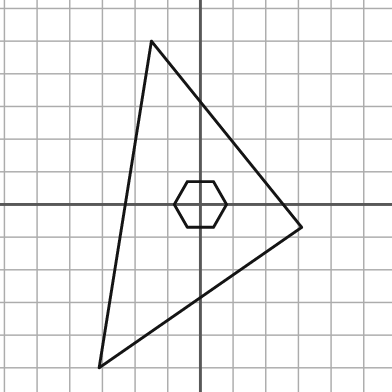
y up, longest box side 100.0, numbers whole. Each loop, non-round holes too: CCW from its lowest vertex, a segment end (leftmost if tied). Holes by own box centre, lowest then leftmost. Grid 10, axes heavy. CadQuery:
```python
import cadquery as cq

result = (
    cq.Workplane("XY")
    .moveTo(-31.0, -50.0)
    .lineTo(31.0, -7.0)
    .lineTo(-15.0, 50.0)
    .close()
    .moveTo(-4.0, -7.0)
    .lineTo(4.0, -7.0)
    .lineTo(8.0, 0.0)
    .lineTo(4.0, 7.0)
    .lineTo(-4.0, 7.0)
    .lineTo(-8.0, 0.0)
    .close()
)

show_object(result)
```